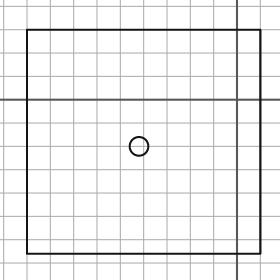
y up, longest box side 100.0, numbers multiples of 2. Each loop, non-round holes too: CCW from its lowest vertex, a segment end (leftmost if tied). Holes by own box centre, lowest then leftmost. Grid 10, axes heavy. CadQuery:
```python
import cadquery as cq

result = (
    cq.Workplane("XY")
    .moveTo(-90.0, -66.0)
    .lineTo(10.0, -66.0)
    .lineTo(10.0, 30.0)
    .lineTo(-90.0, 30.0)
    .close()
    .moveTo(-42.0, -20.0)
    .circle(4.0)
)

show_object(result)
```